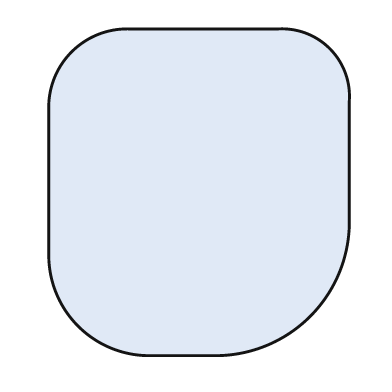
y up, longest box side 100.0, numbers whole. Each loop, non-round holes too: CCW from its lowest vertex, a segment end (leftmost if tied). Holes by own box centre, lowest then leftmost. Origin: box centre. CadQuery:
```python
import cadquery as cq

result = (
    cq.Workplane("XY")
    .moveTo(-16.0, -50.0)
    .lineTo(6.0, -50.0)
    .threePointArc((34.0, -38.0), (46.0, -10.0))
    .lineTo(46.0, 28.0)
    .threePointArc((40.0, 44.0), (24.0, 50.0))
    .lineTo(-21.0, 50.0)
    .threePointArc((-39.0, 43.0), (-46.0, 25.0))
    .lineTo(-46.0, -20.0)
    .threePointArc((-37.0, -41.0), (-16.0, -50.0))
    .close()
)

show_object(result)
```